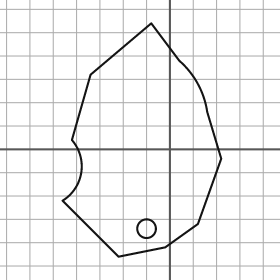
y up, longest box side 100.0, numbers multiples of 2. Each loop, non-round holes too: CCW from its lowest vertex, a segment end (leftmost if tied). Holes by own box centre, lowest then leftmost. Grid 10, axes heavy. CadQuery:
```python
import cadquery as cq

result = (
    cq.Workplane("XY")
    .moveTo(-22.0, -46.0)
    .lineTo(-2.0, -42.0)
    .lineTo(12.0, -32.0)
    .lineTo(22.0, -4.0)
    .lineTo(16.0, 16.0)
    .threePointArc((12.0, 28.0), (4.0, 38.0))
    .lineTo(-8.0, 54.0)
    .lineTo(-34.0, 32.0)
    .lineTo(-42.0, 4.0)
    .threePointArc((-38.0, -10.0), (-46.0, -22.0))
    .close()
    .moveTo(-10.0, -34.0)
    .circle(4.0)
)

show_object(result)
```